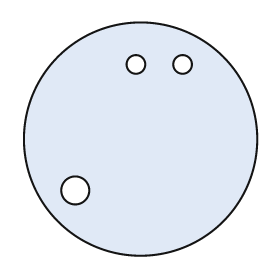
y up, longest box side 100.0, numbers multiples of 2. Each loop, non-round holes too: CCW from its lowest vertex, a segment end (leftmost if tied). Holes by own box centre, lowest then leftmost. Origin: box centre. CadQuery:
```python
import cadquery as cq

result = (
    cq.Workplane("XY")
    .moveTo(0.0, 0.0)
    .circle(50.0)
    .moveTo(-28.0, -22.0)
    .circle(6.0)
    .moveTo(-2.0, 32.0)
    .circle(4.0)
    .moveTo(18.0, 32.0)
    .circle(4.0)
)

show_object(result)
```